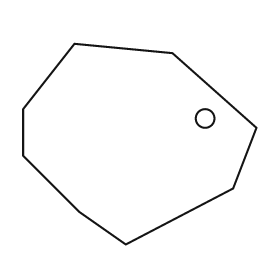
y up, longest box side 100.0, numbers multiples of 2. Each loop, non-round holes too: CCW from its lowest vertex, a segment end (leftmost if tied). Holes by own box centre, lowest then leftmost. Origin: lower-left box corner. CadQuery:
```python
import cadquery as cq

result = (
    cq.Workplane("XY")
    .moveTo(44.0, 0.0)
    .lineTo(90.0, 24.0)
    .lineTo(100.0, 50.0)
    .lineTo(64.0, 82.0)
    .lineTo(22.0, 86.0)
    .lineTo(0.0, 58.0)
    .lineTo(0.0, 38.0)
    .lineTo(24.0, 14.0)
    .close()
    .moveTo(78.0, 54.0)
    .circle(4.0)
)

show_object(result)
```